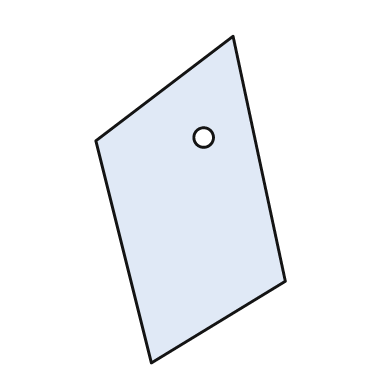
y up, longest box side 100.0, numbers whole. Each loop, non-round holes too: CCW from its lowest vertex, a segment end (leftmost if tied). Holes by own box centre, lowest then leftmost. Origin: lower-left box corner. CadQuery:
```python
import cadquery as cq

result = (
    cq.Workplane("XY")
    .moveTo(17.0, 0.0)
    .lineTo(58.0, 25.0)
    .lineTo(42.0, 100.0)
    .lineTo(0.0, 68.0)
    .close()
    .moveTo(33.0, 69.0)
    .circle(3.0)
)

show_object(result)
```